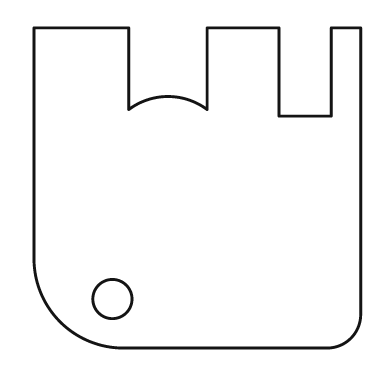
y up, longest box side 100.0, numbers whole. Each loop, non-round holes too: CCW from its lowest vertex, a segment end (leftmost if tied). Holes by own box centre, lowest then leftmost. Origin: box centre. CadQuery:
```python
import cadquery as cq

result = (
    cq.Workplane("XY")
    .moveTo(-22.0, -49.0)
    .lineTo(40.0, -49.0)
    .threePointArc((47.0, -46.0), (50.0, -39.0))
    .lineTo(50.0, 49.0)
    .lineTo(41.0, 49.0)
    .lineTo(41.0, 22.0)
    .lineTo(25.0, 22.0)
    .lineTo(25.0, 49.0)
    .lineTo(3.0, 49.0)
    .lineTo(3.0, 24.0)
    .threePointArc((-9.0, 28.0), (-21.0, 24.0))
    .lineTo(-21.0, 49.0)
    .lineTo(-50.0, 49.0)
    .lineTo(-50.0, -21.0)
    .threePointArc((-42.0, -41.0), (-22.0, -49.0))
    .close()
    .moveTo(-26.0, -34.0)
    .circle(6.0)
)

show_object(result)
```